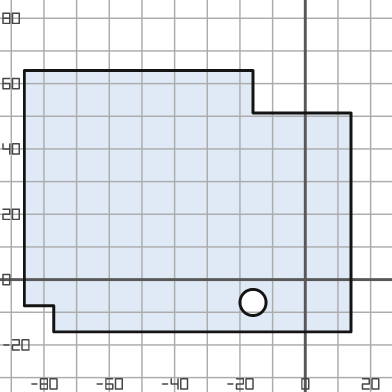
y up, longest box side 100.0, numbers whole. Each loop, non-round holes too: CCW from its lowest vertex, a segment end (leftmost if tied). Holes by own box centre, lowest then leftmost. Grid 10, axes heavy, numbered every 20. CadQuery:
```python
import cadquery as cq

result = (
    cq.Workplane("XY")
    .moveTo(-77.0, -16.0)
    .lineTo(14.0, -16.0)
    .lineTo(14.0, 51.0)
    .lineTo(-16.0, 51.0)
    .lineTo(-16.0, 64.0)
    .lineTo(-86.0, 64.0)
    .lineTo(-86.0, -8.0)
    .lineTo(-77.0, -8.0)
    .close()
    .moveTo(-16.0, -7.0)
    .circle(4.0)
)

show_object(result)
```